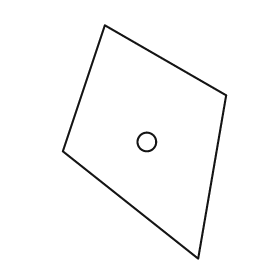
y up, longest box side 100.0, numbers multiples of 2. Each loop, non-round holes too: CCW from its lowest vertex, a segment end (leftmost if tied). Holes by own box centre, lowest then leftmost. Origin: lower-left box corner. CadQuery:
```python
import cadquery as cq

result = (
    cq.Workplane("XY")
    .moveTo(58.0, 0.0)
    .lineTo(70.0, 70.0)
    .lineTo(18.0, 100.0)
    .lineTo(0.0, 46.0)
    .close()
    .moveTo(36.0, 50.0)
    .circle(4.0)
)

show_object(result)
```